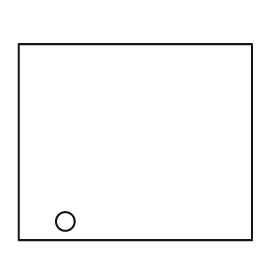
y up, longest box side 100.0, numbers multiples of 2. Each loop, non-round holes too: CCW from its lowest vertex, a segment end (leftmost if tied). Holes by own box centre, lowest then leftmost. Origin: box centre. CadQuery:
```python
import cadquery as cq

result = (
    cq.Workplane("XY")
    .moveTo(-50.0, -42.0)
    .lineTo(50.0, -42.0)
    .lineTo(50.0, 42.0)
    .lineTo(-50.0, 42.0)
    .close()
    .moveTo(-30.0, -34.0)
    .circle(4.0)
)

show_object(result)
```